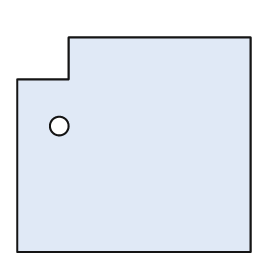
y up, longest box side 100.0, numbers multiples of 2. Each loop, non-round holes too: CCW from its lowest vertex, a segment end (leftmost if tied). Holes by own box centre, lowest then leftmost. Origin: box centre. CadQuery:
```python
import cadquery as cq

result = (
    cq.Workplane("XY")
    .moveTo(-50.0, -46.0)
    .lineTo(50.0, -46.0)
    .lineTo(50.0, 46.0)
    .lineTo(-28.0, 46.0)
    .lineTo(-28.0, 28.0)
    .lineTo(-50.0, 28.0)
    .close()
    .moveTo(-32.0, 8.0)
    .circle(4.0)
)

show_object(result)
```